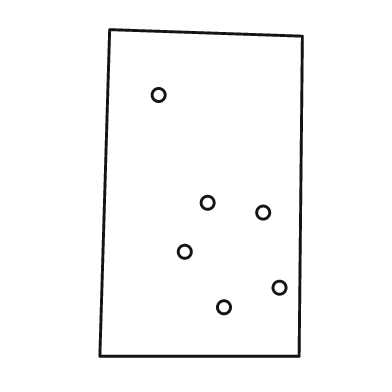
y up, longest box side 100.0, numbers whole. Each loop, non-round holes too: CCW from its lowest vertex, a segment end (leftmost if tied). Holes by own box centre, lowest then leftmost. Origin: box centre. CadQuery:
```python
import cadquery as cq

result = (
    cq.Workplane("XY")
    .moveTo(-31.0, -50.0)
    .lineTo(30.0, -50.0)
    .lineTo(31.0, 48.0)
    .lineTo(-28.0, 50.0)
    .close()
    .moveTo(7.0, -35.0)
    .circle(2.0)
    .moveTo(24.0, -29.0)
    .circle(2.0)
    .moveTo(-5.0, -18.0)
    .circle(2.0)
    .moveTo(19.0, -6.0)
    .circle(2.0)
    .moveTo(2.0, -3.0)
    .circle(2.0)
    .moveTo(-13.0, 30.0)
    .circle(2.0)
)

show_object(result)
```